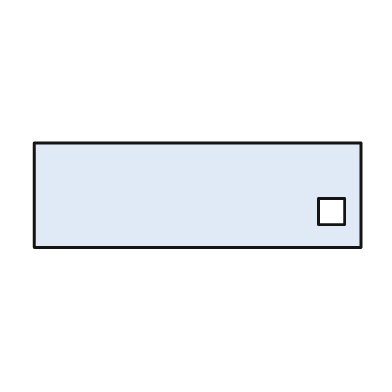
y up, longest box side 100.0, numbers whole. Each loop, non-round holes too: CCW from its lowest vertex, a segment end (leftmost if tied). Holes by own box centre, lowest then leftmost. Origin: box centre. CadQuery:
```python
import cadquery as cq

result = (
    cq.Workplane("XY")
    .moveTo(-50.0, -16.0)
    .lineTo(50.0, -16.0)
    .lineTo(50.0, 16.0)
    .lineTo(-50.0, 16.0)
    .close()
    .moveTo(37.0, -9.0)
    .lineTo(45.0, -9.0)
    .lineTo(45.0, -1.0)
    .lineTo(37.0, -1.0)
    .close()
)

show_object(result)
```